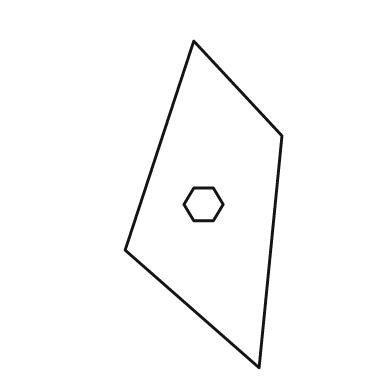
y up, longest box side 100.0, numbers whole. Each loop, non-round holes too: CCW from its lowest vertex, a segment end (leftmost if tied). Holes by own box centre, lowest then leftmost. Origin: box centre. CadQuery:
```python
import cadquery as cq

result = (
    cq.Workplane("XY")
    .moveTo(17.0, -50.0)
    .lineTo(24.0, 21.0)
    .lineTo(-3.0, 50.0)
    .lineTo(-24.0, -14.0)
    .close()
    .moveTo(-3.0, -5.0)
    .lineTo(3.0, -5.0)
    .lineTo(6.0, 0.0)
    .lineTo(3.0, 5.0)
    .lineTo(-3.0, 5.0)
    .lineTo(-6.0, 0.0)
    .close()
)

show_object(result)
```